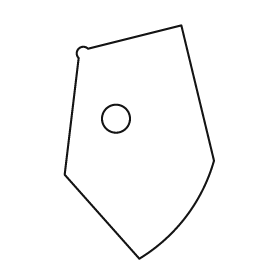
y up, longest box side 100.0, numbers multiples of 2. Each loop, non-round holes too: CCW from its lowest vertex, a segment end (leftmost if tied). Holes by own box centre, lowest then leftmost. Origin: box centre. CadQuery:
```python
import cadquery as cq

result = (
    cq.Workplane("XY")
    .moveTo(0.0, -50.0)
    .threePointArc((20.0, -32.0), (32.0, -8.0))
    .lineTo(18.0, 50.0)
    .lineTo(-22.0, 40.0)
    .threePointArc((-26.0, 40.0), (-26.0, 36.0))
    .lineTo(-32.0, -14.0)
    .close()
    .moveTo(-10.0, 10.0)
    .circle(6.0)
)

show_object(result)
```